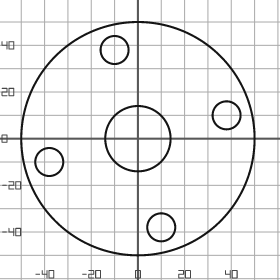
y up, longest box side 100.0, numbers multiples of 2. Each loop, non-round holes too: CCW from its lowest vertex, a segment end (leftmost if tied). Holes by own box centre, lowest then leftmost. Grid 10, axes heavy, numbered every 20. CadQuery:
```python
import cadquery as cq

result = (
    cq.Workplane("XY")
    .moveTo(0.0, 0.0)
    .circle(50.0)
    .moveTo(10.0, -38.0)
    .circle(6.0)
    .moveTo(-38.0, -10.0)
    .circle(6.0)
    .moveTo(0.0, 0.0)
    .circle(14.0)
    .moveTo(38.0, 10.0)
    .circle(6.0)
    .moveTo(-10.0, 38.0)
    .circle(6.0)
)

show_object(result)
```